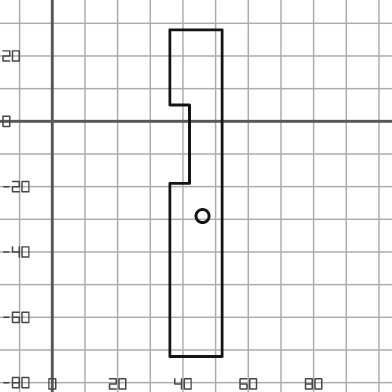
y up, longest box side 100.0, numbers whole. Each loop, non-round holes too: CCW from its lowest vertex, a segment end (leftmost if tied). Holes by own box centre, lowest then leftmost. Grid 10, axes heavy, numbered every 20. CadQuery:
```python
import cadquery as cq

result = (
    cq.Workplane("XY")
    .moveTo(36.0, -72.0)
    .lineTo(52.0, -72.0)
    .lineTo(52.0, 28.0)
    .lineTo(36.0, 28.0)
    .lineTo(36.0, 5.0)
    .lineTo(42.0, 5.0)
    .lineTo(42.0, -19.0)
    .lineTo(36.0, -19.0)
    .close()
    .moveTo(46.0, -29.0)
    .circle(2.0)
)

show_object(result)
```